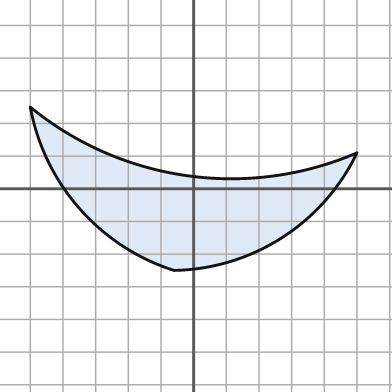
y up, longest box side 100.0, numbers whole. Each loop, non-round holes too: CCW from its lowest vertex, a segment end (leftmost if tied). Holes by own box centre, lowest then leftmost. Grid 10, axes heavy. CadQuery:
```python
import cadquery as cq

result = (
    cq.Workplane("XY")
    .moveTo(-6.0, -25.0)
    .threePointArc((27.0, -15.0), (50.0, 11.0))
    .threePointArc((-2.0, 4.0), (-50.0, 25.0))
    .threePointArc((-35.0, -6.0), (-6.0, -25.0))
    .close()
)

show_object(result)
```